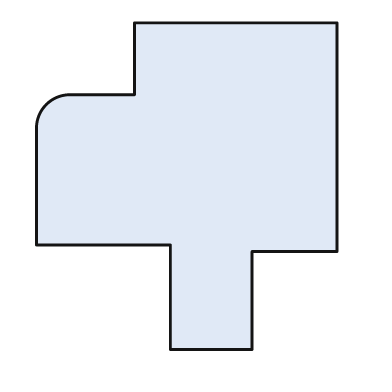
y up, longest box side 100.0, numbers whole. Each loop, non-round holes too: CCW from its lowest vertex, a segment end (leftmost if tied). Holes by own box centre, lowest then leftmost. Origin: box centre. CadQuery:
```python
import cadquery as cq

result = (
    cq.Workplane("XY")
    .moveTo(-5.0, -50.0)
    .lineTo(20.0, -50.0)
    .lineTo(20.0, -20.0)
    .lineTo(46.0, -20.0)
    .lineTo(46.0, 50.0)
    .lineTo(-16.0, 50.0)
    .lineTo(-16.0, 28.0)
    .lineTo(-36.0, 28.0)
    .threePointArc((-43.0, 25.0), (-46.0, 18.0))
    .lineTo(-46.0, -18.0)
    .lineTo(-5.0, -18.0)
    .close()
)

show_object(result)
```